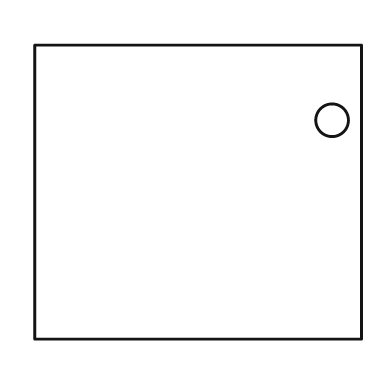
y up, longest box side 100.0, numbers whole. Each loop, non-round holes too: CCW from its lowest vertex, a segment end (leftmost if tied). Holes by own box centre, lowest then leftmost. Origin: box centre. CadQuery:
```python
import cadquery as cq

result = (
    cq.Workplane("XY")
    .moveTo(-50.0, -45.0)
    .lineTo(50.0, -45.0)
    .lineTo(50.0, 45.0)
    .lineTo(-50.0, 45.0)
    .close()
    .moveTo(41.0, 22.0)
    .circle(5.0)
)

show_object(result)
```